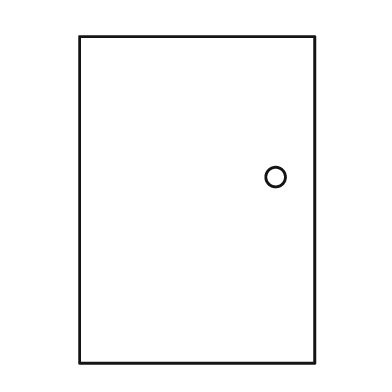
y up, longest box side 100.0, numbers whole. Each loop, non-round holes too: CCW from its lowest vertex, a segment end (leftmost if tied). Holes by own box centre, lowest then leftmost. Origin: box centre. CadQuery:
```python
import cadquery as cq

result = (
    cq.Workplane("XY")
    .moveTo(-36.0, -50.0)
    .lineTo(36.0, -50.0)
    .lineTo(36.0, 50.0)
    .lineTo(-36.0, 50.0)
    .close()
    .moveTo(24.0, 7.0)
    .circle(3.0)
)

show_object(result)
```